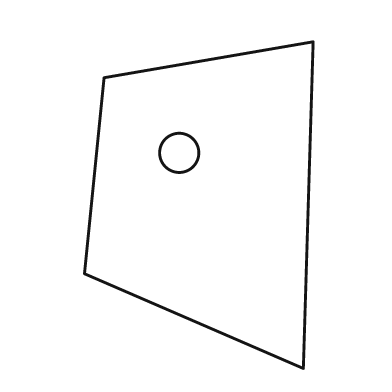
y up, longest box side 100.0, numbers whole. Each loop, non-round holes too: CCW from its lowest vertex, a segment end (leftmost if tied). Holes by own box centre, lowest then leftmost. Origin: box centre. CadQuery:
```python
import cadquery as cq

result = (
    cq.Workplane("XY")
    .moveTo(32.0, -50.0)
    .lineTo(35.0, 50.0)
    .lineTo(-29.0, 39.0)
    .lineTo(-35.0, -21.0)
    .close()
    .moveTo(-6.0, 16.0)
    .circle(6.0)
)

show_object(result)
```